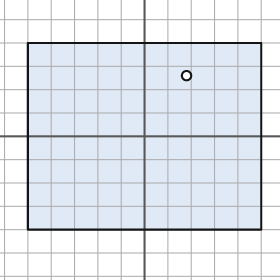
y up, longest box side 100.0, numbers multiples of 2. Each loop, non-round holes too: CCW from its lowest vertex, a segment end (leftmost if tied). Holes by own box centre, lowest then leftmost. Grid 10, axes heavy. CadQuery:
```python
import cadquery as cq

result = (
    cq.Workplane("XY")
    .moveTo(-50.0, -40.0)
    .lineTo(50.0, -40.0)
    .lineTo(50.0, 40.0)
    .lineTo(-50.0, 40.0)
    .close()
    .moveTo(18.0, 26.0)
    .circle(2.0)
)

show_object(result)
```